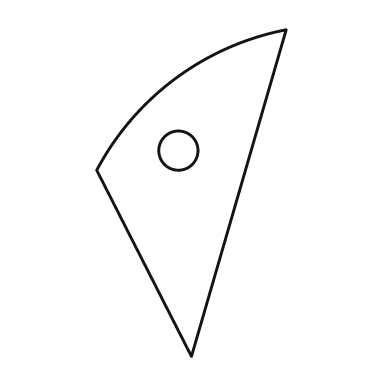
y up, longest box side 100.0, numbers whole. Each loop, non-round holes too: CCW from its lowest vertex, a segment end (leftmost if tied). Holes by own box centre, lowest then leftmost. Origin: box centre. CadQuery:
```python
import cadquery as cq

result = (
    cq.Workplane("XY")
    .moveTo(0.0, -50.0)
    .lineTo(29.0, 50.0)
    .threePointArc((-5.0, 35.0), (-29.0, 7.0))
    .close()
    .moveTo(-4.0, 13.0)
    .circle(6.0)
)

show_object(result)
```